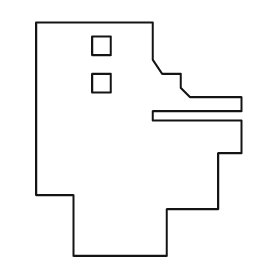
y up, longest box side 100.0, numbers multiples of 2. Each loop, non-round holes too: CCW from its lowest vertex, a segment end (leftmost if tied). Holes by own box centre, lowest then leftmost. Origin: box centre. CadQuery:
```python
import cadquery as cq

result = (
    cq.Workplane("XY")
    .moveTo(-28.0, -50.0)
    .lineTo(12.0, -50.0)
    .lineTo(12.0, -30.0)
    .lineTo(34.0, -30.0)
    .lineTo(34.0, -6.0)
    .lineTo(44.0, -6.0)
    .lineTo(44.0, 8.0)
    .lineTo(6.0, 8.0)
    .lineTo(6.0, 12.0)
    .lineTo(44.0, 12.0)
    .lineTo(44.0, 18.0)
    .lineTo(22.0, 18.0)
    .lineTo(18.0, 22.0)
    .lineTo(18.0, 28.0)
    .lineTo(10.0, 28.0)
    .lineTo(6.0, 34.0)
    .lineTo(6.0, 50.0)
    .lineTo(-44.0, 50.0)
    .lineTo(-44.0, -24.0)
    .lineTo(-28.0, -24.0)
    .close()
    .moveTo(-20.0, 20.0)
    .lineTo(-12.0, 20.0)
    .lineTo(-12.0, 28.0)
    .lineTo(-20.0, 28.0)
    .close()
    .moveTo(-20.0, 36.0)
    .lineTo(-12.0, 36.0)
    .lineTo(-12.0, 44.0)
    .lineTo(-20.0, 44.0)
    .close()
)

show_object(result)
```